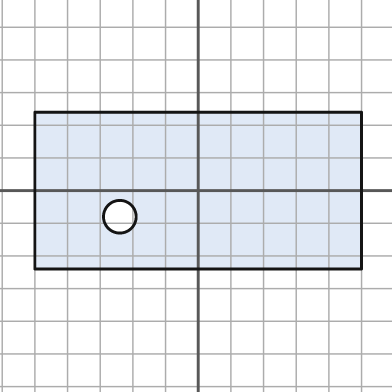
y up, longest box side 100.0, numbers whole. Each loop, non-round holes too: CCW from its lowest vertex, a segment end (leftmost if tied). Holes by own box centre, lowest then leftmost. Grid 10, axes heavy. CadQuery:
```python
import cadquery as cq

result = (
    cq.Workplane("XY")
    .moveTo(-50.0, -24.0)
    .lineTo(50.0, -24.0)
    .lineTo(50.0, 24.0)
    .lineTo(-50.0, 24.0)
    .close()
    .moveTo(-24.0, -8.0)
    .circle(5.0)
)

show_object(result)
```